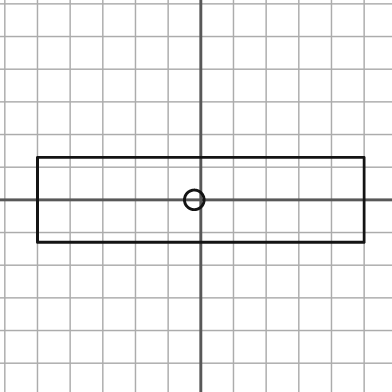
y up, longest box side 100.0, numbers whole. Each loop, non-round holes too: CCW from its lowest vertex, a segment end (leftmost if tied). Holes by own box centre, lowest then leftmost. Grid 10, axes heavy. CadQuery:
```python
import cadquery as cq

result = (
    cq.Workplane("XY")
    .moveTo(-50.0, -13.0)
    .lineTo(50.0, -13.0)
    .lineTo(50.0, 13.0)
    .lineTo(-50.0, 13.0)
    .close()
    .moveTo(-2.0, 0.0)
    .circle(3.0)
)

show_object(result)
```